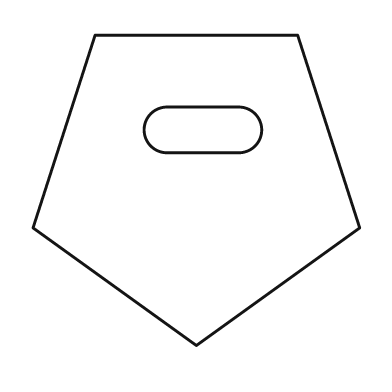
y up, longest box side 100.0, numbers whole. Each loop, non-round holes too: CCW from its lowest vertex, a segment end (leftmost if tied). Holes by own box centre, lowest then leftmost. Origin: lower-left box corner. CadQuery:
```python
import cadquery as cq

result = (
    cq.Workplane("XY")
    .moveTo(50.0, 0.0)
    .lineTo(100.0, 36.0)
    .lineTo(81.0, 95.0)
    .lineTo(19.0, 95.0)
    .lineTo(0.0, 36.0)
    .close()
    .moveTo(41.0, 59.0)
    .lineTo(63.0, 59.0)
    .threePointArc((70.0, 66.0), (63.0, 73.0))
    .lineTo(41.0, 73.0)
    .threePointArc((34.0, 66.0), (41.0, 59.0))
    .close()
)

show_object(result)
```